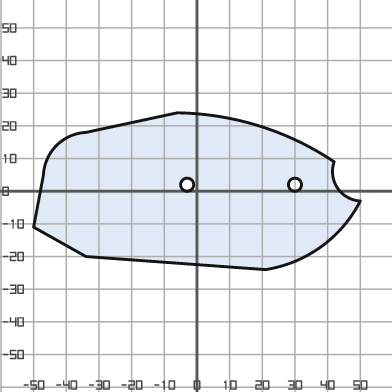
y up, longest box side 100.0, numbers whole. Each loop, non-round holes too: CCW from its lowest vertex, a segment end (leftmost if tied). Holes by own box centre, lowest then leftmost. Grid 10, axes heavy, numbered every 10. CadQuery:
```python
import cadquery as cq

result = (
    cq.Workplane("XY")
    .moveTo(21.0, -24.0)
    .threePointArc((38.0, -17.0), (50.0, -3.0))
    .threePointArc((43.0, 1.0), (42.0, 9.0))
    .threePointArc((19.0, 20.0), (-6.0, 24.0))
    .lineTo(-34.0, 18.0)
    .threePointArc((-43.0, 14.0), (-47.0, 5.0))
    .lineTo(-50.0, -11.0)
    .lineTo(-34.0, -20.0)
    .close()
    .moveTo(-3.0, 2.0)
    .circle(2.0)
    .moveTo(30.0, 2.0)
    .circle(2.0)
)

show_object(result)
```